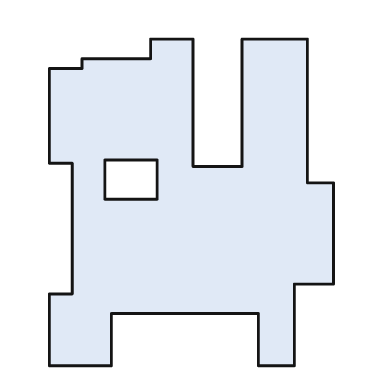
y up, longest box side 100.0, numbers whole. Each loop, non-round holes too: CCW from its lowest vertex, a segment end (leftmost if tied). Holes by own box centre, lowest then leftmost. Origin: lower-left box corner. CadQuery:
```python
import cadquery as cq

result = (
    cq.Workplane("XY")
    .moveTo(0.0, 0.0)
    .lineTo(19.0, 0.0)
    .lineTo(19.0, 16.0)
    .lineTo(64.0, 16.0)
    .lineTo(64.0, 0.0)
    .lineTo(75.0, 0.0)
    .lineTo(75.0, 25.0)
    .lineTo(87.0, 25.0)
    .lineTo(87.0, 56.0)
    .lineTo(79.0, 56.0)
    .lineTo(79.0, 100.0)
    .lineTo(59.0, 100.0)
    .lineTo(59.0, 61.0)
    .lineTo(44.0, 61.0)
    .lineTo(44.0, 100.0)
    .lineTo(31.0, 100.0)
    .lineTo(31.0, 94.0)
    .lineTo(10.0, 94.0)
    .lineTo(10.0, 91.0)
    .lineTo(0.0, 91.0)
    .lineTo(0.0, 62.0)
    .lineTo(7.0, 62.0)
    .lineTo(7.0, 22.0)
    .lineTo(0.0, 22.0)
    .close()
    .moveTo(17.0, 51.0)
    .lineTo(33.0, 51.0)
    .lineTo(33.0, 63.0)
    .lineTo(17.0, 63.0)
    .close()
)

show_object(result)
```